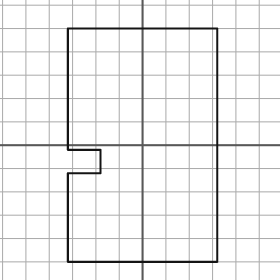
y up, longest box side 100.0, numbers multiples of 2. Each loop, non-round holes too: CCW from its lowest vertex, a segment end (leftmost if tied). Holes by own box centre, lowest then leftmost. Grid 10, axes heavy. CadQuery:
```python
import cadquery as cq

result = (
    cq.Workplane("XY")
    .moveTo(-32.0, -50.0)
    .lineTo(32.0, -50.0)
    .lineTo(32.0, 50.0)
    .lineTo(-32.0, 50.0)
    .lineTo(-32.0, -2.0)
    .lineTo(-18.0, -2.0)
    .lineTo(-18.0, -12.0)
    .lineTo(-32.0, -12.0)
    .close()
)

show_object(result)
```